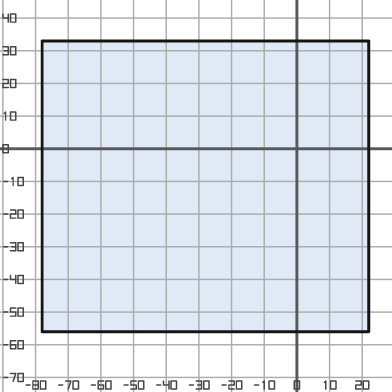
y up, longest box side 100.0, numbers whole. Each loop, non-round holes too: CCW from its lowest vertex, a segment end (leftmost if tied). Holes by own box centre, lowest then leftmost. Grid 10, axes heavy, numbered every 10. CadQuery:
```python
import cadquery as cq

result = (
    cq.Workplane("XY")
    .moveTo(-78.0, -56.0)
    .lineTo(22.0, -56.0)
    .lineTo(22.0, 33.0)
    .lineTo(-78.0, 33.0)
    .close()
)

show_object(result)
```